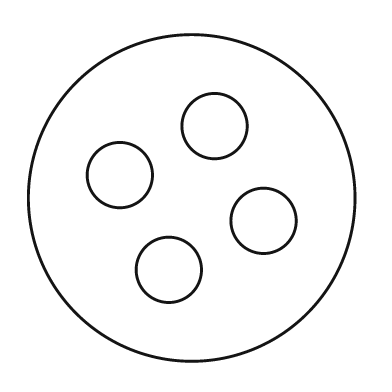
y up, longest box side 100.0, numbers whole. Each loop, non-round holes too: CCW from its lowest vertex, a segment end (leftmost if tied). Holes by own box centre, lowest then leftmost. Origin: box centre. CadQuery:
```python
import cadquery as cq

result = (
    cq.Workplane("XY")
    .moveTo(0.0, 0.0)
    .circle(50.0)
    .moveTo(-7.0, -22.0)
    .circle(10.0)
    .moveTo(22.0, -7.0)
    .circle(10.0)
    .moveTo(-22.0, 7.0)
    .circle(10.0)
    .moveTo(7.0, 22.0)
    .circle(10.0)
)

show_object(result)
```